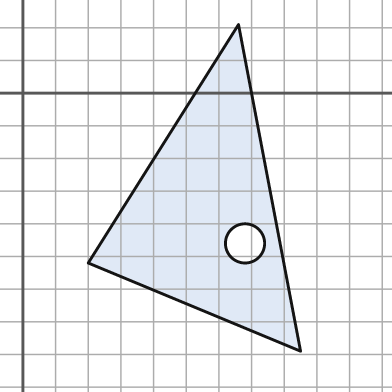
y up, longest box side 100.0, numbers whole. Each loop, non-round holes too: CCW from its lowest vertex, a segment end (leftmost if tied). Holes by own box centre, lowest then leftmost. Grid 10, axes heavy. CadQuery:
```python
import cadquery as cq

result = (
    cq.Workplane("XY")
    .moveTo(85.0, -79.0)
    .lineTo(66.0, 21.0)
    .lineTo(20.0, -52.0)
    .close()
    .moveTo(68.0, -46.0)
    .circle(6.0)
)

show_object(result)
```